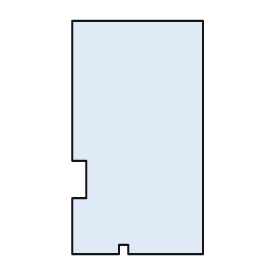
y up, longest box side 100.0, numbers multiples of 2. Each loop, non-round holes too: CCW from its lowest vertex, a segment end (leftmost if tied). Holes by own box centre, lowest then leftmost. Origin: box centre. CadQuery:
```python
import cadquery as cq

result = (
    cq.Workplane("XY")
    .moveTo(-28.0, -50.0)
    .lineTo(-8.0, -50.0)
    .lineTo(-8.0, -46.0)
    .lineTo(-4.0, -46.0)
    .lineTo(-4.0, -50.0)
    .lineTo(28.0, -50.0)
    .lineTo(28.0, 50.0)
    .lineTo(-28.0, 50.0)
    .lineTo(-28.0, -10.0)
    .lineTo(-22.0, -10.0)
    .lineTo(-22.0, -26.0)
    .lineTo(-28.0, -26.0)
    .close()
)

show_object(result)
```